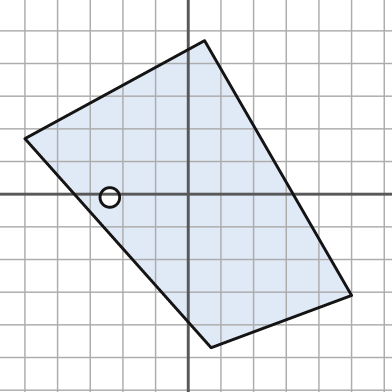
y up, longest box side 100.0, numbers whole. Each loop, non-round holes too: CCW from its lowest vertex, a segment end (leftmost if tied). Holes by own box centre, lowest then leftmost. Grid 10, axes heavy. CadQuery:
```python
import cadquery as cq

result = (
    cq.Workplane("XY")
    .moveTo(7.0, -47.0)
    .lineTo(50.0, -31.0)
    .lineTo(5.0, 47.0)
    .lineTo(-50.0, 17.0)
    .close()
    .moveTo(-24.0, -1.0)
    .circle(3.0)
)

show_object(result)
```